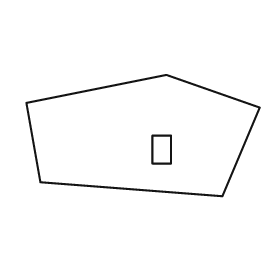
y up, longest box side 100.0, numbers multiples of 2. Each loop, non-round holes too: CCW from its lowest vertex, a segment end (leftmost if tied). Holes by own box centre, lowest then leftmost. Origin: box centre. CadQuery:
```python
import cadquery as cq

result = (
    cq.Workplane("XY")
    .moveTo(34.0, -26.0)
    .lineTo(50.0, 12.0)
    .lineTo(10.0, 26.0)
    .lineTo(-50.0, 14.0)
    .lineTo(-44.0, -20.0)
    .close()
    .moveTo(4.0, -12.0)
    .lineTo(12.0, -12.0)
    .lineTo(12.0, 0.0)
    .lineTo(4.0, 0.0)
    .close()
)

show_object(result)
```